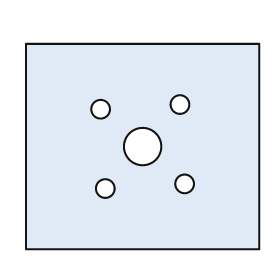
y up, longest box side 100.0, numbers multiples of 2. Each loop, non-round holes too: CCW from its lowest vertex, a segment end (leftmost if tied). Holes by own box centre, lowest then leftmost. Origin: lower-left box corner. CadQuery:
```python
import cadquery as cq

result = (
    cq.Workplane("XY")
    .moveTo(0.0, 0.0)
    .lineTo(100.0, 0.0)
    .lineTo(100.0, 88.0)
    .lineTo(0.0, 88.0)
    .close()
    .moveTo(34.0, 26.0)
    .circle(4.0)
    .moveTo(68.0, 28.0)
    .circle(4.0)
    .moveTo(50.0, 44.0)
    .circle(8.0)
    .moveTo(32.0, 60.0)
    .circle(4.0)
    .moveTo(66.0, 62.0)
    .circle(4.0)
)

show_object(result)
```